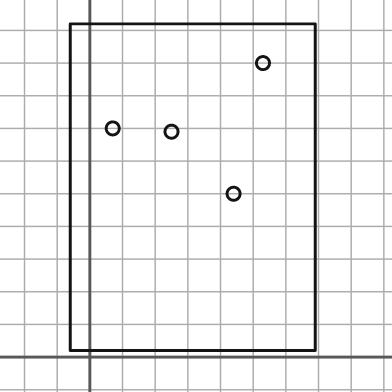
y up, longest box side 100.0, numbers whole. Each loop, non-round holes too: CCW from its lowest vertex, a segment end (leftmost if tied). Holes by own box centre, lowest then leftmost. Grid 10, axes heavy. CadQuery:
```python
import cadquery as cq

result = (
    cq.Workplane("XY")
    .moveTo(-6.0, 2.0)
    .lineTo(69.0, 2.0)
    .lineTo(69.0, 102.0)
    .lineTo(-6.0, 102.0)
    .close()
    .moveTo(44.0, 50.0)
    .circle(2.0)
    .moveTo(25.0, 69.0)
    .circle(2.0)
    .moveTo(7.0, 70.0)
    .circle(2.0)
    .moveTo(53.0, 90.0)
    .circle(2.0)
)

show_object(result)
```